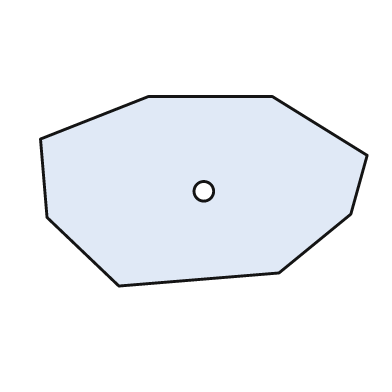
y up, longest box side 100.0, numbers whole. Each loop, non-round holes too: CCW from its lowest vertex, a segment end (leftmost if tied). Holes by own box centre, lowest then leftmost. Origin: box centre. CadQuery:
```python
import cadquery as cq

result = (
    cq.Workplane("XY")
    .moveTo(-26.0, -29.0)
    .lineTo(23.0, -25.0)
    .lineTo(45.0, -7.0)
    .lineTo(50.0, 11.0)
    .lineTo(21.0, 29.0)
    .lineTo(-17.0, 29.0)
    .lineTo(-50.0, 16.0)
    .lineTo(-48.0, -8.0)
    .close()
    .moveTo(0.0, 0.0)
    .circle(3.0)
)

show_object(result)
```